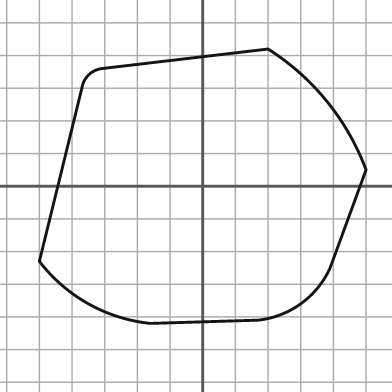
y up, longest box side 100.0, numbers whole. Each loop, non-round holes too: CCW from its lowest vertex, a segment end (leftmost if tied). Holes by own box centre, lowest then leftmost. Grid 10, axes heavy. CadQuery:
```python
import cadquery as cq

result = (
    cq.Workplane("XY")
    .moveTo(-16.0, -42.0)
    .lineTo(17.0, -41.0)
    .threePointArc((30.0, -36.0), (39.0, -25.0))
    .lineTo(50.0, 5.0)
    .threePointArc((38.0, 26.0), (20.0, 42.0))
    .lineTo(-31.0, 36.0)
    .threePointArc((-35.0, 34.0), (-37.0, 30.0))
    .lineTo(-50.0, -23.0)
    .threePointArc((-35.0, -36.0), (-16.0, -42.0))
    .close()
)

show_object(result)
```